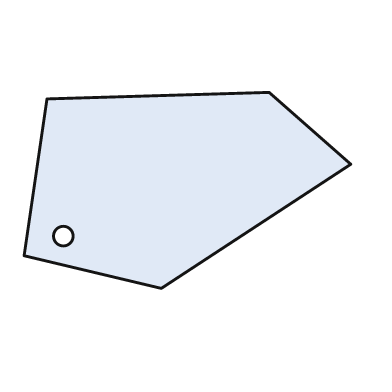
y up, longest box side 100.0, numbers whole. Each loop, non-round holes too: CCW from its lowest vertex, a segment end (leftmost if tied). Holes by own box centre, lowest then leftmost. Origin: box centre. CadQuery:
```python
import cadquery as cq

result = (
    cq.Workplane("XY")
    .moveTo(-8.0, -30.0)
    .lineTo(50.0, 8.0)
    .lineTo(25.0, 30.0)
    .lineTo(-43.0, 28.0)
    .lineTo(-50.0, -20.0)
    .close()
    .moveTo(-38.0, -14.0)
    .circle(3.0)
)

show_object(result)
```